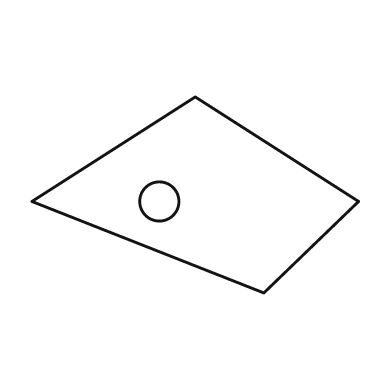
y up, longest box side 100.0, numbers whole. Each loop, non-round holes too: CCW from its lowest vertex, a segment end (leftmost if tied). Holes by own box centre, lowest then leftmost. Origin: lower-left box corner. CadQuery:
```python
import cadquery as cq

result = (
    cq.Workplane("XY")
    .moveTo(71.0, 0.0)
    .lineTo(100.0, 28.0)
    .lineTo(50.0, 60.0)
    .lineTo(0.0, 28.0)
    .close()
    .moveTo(39.0, 28.0)
    .circle(6.0)
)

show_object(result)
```